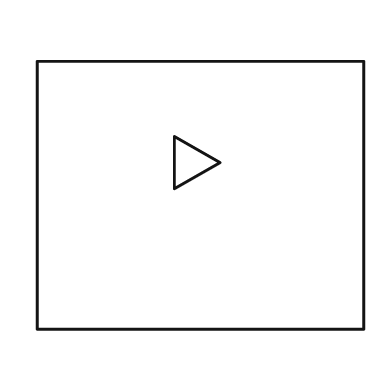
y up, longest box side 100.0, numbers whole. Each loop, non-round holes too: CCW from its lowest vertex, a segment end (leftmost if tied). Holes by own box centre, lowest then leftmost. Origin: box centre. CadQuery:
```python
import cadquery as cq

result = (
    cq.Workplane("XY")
    .moveTo(-50.0, -41.0)
    .lineTo(50.0, -41.0)
    .lineTo(50.0, 41.0)
    .lineTo(-50.0, 41.0)
    .close()
    .moveTo(-8.0, 2.0)
    .lineTo(6.0, 10.0)
    .lineTo(-8.0, 18.0)
    .close()
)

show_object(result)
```